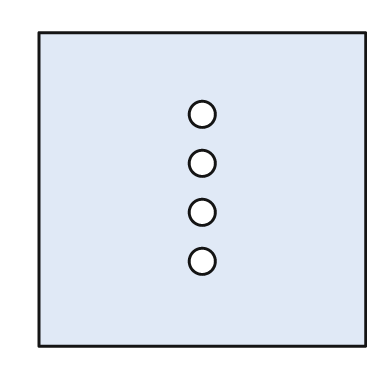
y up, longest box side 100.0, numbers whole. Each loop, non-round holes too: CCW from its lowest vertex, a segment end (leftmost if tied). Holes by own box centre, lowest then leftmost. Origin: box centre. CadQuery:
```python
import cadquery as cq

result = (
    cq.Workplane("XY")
    .moveTo(-50.0, -48.0)
    .lineTo(50.0, -48.0)
    .lineTo(50.0, 48.0)
    .lineTo(-50.0, 48.0)
    .close()
    .moveTo(0.0, -22.0)
    .circle(4.0)
    .moveTo(0.0, -7.0)
    .circle(4.0)
    .moveTo(0.0, 8.0)
    .circle(4.0)
    .moveTo(0.0, 23.0)
    .circle(4.0)
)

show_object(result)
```